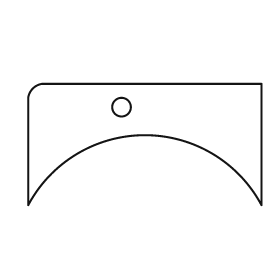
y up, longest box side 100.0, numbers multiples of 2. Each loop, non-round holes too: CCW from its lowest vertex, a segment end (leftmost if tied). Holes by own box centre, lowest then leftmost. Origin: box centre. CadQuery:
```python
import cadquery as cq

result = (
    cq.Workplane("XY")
    .moveTo(-50.0, -26.0)
    .threePointArc((0.0, 4.0), (50.0, -26.0))
    .lineTo(50.0, 26.0)
    .lineTo(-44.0, 26.0)
    .threePointArc((-48.0, 24.0), (-50.0, 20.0))
    .close()
    .moveTo(-10.0, 16.0)
    .circle(4.0)
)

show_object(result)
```